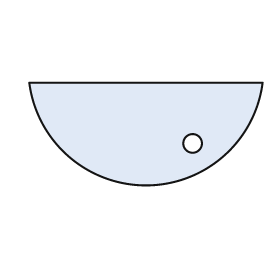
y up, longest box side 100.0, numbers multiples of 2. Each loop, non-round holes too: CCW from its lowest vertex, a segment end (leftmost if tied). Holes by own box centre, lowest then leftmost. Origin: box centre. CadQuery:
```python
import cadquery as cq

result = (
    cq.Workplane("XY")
    .moveTo(-50.0, 22.0)
    .threePointArc((0.0, -22.0), (50.0, 22.0))
    .close()
    .moveTo(20.0, -4.0)
    .circle(4.0)
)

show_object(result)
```